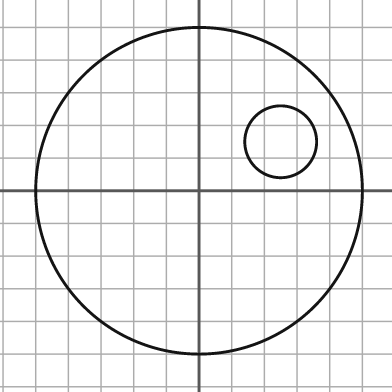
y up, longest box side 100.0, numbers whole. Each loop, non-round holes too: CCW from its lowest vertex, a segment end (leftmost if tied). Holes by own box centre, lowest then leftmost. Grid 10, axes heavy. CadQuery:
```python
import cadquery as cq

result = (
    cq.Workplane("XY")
    .moveTo(0.0, 0.0)
    .circle(50.0)
    .moveTo(25.0, 15.0)
    .circle(11.0)
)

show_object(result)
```